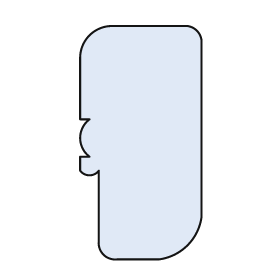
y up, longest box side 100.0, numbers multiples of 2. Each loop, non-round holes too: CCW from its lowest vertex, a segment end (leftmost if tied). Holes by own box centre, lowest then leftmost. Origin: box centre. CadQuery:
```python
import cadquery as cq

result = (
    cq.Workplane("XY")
    .moveTo(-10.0, -50.0)
    .lineTo(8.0, -50.0)
    .threePointArc((20.0, -44.0), (26.0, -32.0))
    .lineTo(26.0, 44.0)
    .threePointArc((24.0, 48.0), (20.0, 50.0))
    .lineTo(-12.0, 50.0)
    .threePointArc((-22.0, 46.0), (-26.0, 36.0))
    .lineTo(-26.0, 10.0)
    .lineTo(-22.0, 10.0)
    .threePointArc((-26.0, 2.0), (-22.0, -6.0))
    .lineTo(-26.0, -6.0)
    .lineTo(-26.0, -12.0)
    .threePointArc((-22.0, -14.0), (-18.0, -12.0))
    .lineTo(-18.0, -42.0)
    .threePointArc((-16.0, -48.0), (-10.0, -50.0))
    .close()
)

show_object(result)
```